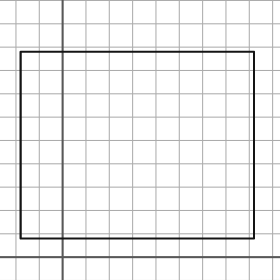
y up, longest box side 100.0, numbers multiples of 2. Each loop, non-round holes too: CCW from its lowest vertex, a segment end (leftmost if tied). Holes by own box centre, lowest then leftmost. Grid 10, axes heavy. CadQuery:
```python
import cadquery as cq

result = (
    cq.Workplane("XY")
    .moveTo(-18.0, 8.0)
    .lineTo(82.0, 8.0)
    .lineTo(82.0, 88.0)
    .lineTo(-18.0, 88.0)
    .close()
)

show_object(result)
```